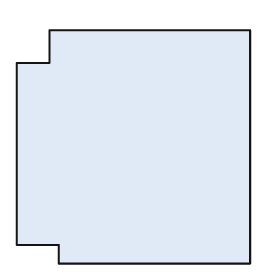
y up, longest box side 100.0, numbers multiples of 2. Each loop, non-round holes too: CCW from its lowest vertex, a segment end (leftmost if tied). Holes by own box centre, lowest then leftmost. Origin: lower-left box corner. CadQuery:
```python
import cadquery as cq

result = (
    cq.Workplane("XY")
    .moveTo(18.0, 0.0)
    .lineTo(100.0, 0.0)
    .lineTo(100.0, 100.0)
    .lineTo(14.0, 100.0)
    .lineTo(14.0, 86.0)
    .lineTo(0.0, 86.0)
    .lineTo(0.0, 8.0)
    .lineTo(18.0, 8.0)
    .close()
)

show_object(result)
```